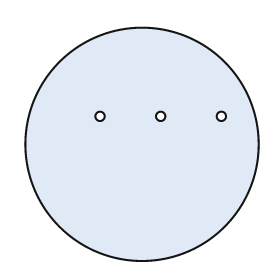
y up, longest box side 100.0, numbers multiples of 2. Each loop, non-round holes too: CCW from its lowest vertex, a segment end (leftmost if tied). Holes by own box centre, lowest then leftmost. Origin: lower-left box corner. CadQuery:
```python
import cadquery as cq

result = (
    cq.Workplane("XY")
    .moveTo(50.0, 50.0)
    .circle(50.0)
    .moveTo(32.0, 62.0)
    .circle(2.0)
    .moveTo(58.0, 62.0)
    .circle(2.0)
    .moveTo(84.0, 62.0)
    .circle(2.0)
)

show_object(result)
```